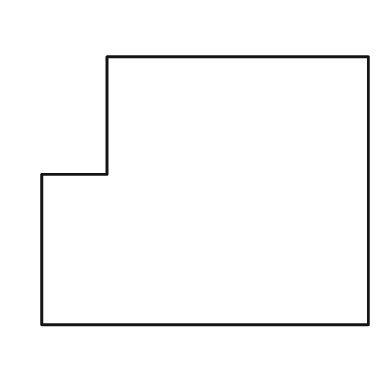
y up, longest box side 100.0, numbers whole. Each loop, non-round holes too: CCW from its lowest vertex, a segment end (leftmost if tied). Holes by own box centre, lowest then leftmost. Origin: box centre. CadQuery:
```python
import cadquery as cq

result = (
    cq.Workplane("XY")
    .moveTo(-50.0, -41.0)
    .lineTo(50.0, -41.0)
    .lineTo(50.0, 41.0)
    .lineTo(-30.0, 41.0)
    .lineTo(-30.0, 5.0)
    .lineTo(-50.0, 5.0)
    .close()
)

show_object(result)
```